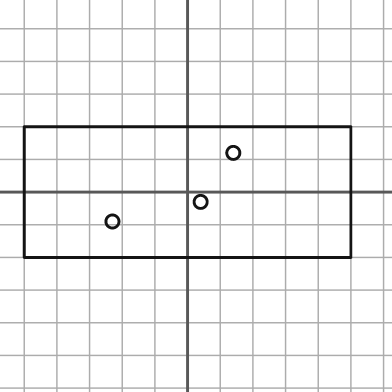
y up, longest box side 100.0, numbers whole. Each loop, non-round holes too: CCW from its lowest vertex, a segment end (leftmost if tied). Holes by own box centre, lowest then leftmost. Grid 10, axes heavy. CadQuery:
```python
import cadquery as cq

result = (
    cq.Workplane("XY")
    .moveTo(-50.0, -20.0)
    .lineTo(50.0, -20.0)
    .lineTo(50.0, 20.0)
    .lineTo(-50.0, 20.0)
    .close()
    .moveTo(-23.0, -9.0)
    .circle(2.0)
    .moveTo(4.0, -3.0)
    .circle(2.0)
    .moveTo(14.0, 12.0)
    .circle(2.0)
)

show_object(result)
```